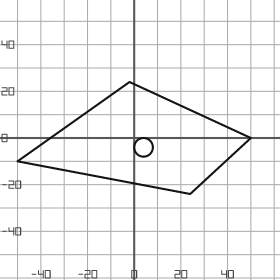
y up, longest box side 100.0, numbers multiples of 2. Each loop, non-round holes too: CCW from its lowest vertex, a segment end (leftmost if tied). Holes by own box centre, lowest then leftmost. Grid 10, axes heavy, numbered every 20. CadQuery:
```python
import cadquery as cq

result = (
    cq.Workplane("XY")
    .moveTo(24.0, -24.0)
    .lineTo(50.0, 0.0)
    .lineTo(-2.0, 24.0)
    .lineTo(-50.0, -10.0)
    .close()
    .moveTo(4.0, -4.0)
    .circle(4.0)
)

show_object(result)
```